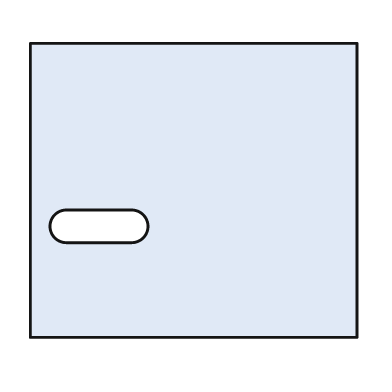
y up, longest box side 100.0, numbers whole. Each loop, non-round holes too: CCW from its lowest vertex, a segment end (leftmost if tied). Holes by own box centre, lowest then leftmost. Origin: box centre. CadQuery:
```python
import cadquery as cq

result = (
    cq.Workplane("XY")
    .moveTo(-50.0, -45.0)
    .lineTo(50.0, -45.0)
    .lineTo(50.0, 45.0)
    .lineTo(-50.0, 45.0)
    .close()
    .moveTo(-39.0, -16.0)
    .lineTo(-19.0, -16.0)
    .threePointArc((-14.0, -11.0), (-19.0, -6.0))
    .lineTo(-39.0, -6.0)
    .threePointArc((-44.0, -11.0), (-39.0, -16.0))
    .close()
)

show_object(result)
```